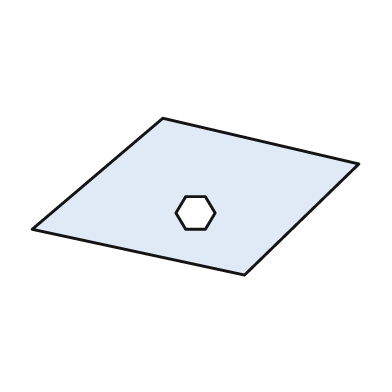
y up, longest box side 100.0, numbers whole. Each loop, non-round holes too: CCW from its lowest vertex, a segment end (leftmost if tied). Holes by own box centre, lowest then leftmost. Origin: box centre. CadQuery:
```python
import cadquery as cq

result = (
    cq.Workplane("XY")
    .moveTo(15.0, -24.0)
    .lineTo(50.0, 10.0)
    .lineTo(-10.0, 24.0)
    .lineTo(-50.0, -10.0)
    .close()
    .moveTo(-3.0, -10.0)
    .lineTo(3.0, -10.0)
    .lineTo(6.0, -5.0)
    .lineTo(3.0, 0.0)
    .lineTo(-3.0, 0.0)
    .lineTo(-6.0, -5.0)
    .close()
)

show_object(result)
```